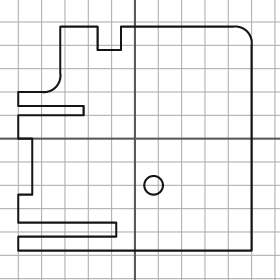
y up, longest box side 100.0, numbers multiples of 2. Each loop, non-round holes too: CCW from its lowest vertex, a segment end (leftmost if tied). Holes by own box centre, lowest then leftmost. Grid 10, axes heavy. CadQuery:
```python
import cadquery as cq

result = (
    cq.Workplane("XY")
    .moveTo(-50.0, -48.0)
    .lineTo(50.0, -48.0)
    .lineTo(50.0, 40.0)
    .threePointArc((48.0, 46.0), (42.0, 48.0))
    .lineTo(-6.0, 48.0)
    .lineTo(-6.0, 38.0)
    .lineTo(-16.0, 38.0)
    .lineTo(-16.0, 48.0)
    .lineTo(-32.0, 48.0)
    .lineTo(-32.0, 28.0)
    .threePointArc((-34.0, 22.0), (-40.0, 20.0))
    .lineTo(-50.0, 20.0)
    .lineTo(-50.0, 14.0)
    .lineTo(-22.0, 14.0)
    .lineTo(-22.0, 10.0)
    .lineTo(-50.0, 10.0)
    .lineTo(-50.0, 0.0)
    .lineTo(-44.0, 0.0)
    .lineTo(-44.0, -24.0)
    .lineTo(-50.0, -24.0)
    .lineTo(-50.0, -36.0)
    .lineTo(-8.0, -36.0)
    .lineTo(-8.0, -42.0)
    .lineTo(-50.0, -42.0)
    .close()
    .moveTo(8.0, -20.0)
    .circle(4.0)
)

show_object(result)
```